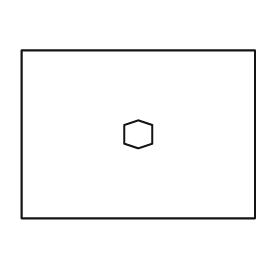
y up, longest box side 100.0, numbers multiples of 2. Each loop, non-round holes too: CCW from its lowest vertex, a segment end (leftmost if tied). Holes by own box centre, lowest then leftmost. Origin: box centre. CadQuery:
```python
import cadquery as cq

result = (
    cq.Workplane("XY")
    .moveTo(-50.0, -36.0)
    .lineTo(50.0, -36.0)
    .lineTo(50.0, 36.0)
    .lineTo(-50.0, 36.0)
    .close()
    .moveTo(0.0, -6.0)
    .lineTo(6.0, -4.0)
    .lineTo(6.0, 4.0)
    .lineTo(0.0, 6.0)
    .lineTo(-6.0, 4.0)
    .lineTo(-6.0, -4.0)
    .close()
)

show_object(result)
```